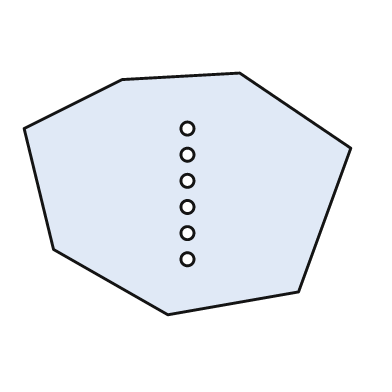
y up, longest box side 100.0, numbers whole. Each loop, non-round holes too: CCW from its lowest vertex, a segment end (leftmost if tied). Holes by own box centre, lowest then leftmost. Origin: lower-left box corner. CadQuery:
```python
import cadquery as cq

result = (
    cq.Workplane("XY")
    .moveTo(44.0, 0.0)
    .lineTo(84.0, 7.0)
    .lineTo(100.0, 51.0)
    .lineTo(66.0, 74.0)
    .lineTo(30.0, 72.0)
    .lineTo(0.0, 57.0)
    .lineTo(9.0, 20.0)
    .close()
    .moveTo(50.0, 17.0)
    .circle(2.0)
    .moveTo(50.0, 25.0)
    .circle(2.0)
    .moveTo(50.0, 33.0)
    .circle(2.0)
    .moveTo(50.0, 41.0)
    .circle(2.0)
    .moveTo(50.0, 49.0)
    .circle(2.0)
    .moveTo(50.0, 57.0)
    .circle(2.0)
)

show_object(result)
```